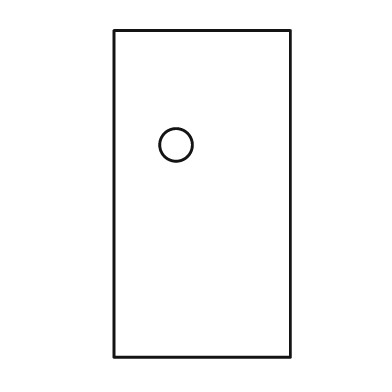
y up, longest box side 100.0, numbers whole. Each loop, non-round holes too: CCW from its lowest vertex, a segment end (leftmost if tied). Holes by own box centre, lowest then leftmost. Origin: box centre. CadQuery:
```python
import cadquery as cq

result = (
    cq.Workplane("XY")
    .moveTo(-27.0, -50.0)
    .lineTo(27.0, -50.0)
    .lineTo(27.0, 50.0)
    .lineTo(-27.0, 50.0)
    .close()
    .moveTo(-8.0, 15.0)
    .circle(5.0)
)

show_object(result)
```